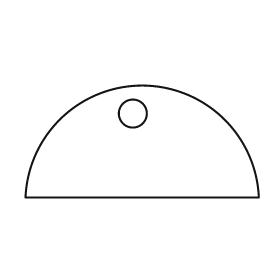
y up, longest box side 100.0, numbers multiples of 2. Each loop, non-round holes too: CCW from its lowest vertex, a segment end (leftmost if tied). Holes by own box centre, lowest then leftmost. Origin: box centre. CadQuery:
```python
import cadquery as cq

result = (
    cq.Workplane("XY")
    .moveTo(-50.0, -24.0)
    .lineTo(50.0, -24.0)
    .threePointArc((0.0, 24.0), (-50.0, -24.0))
    .close()
    .moveTo(-4.0, 12.0)
    .circle(6.0)
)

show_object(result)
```